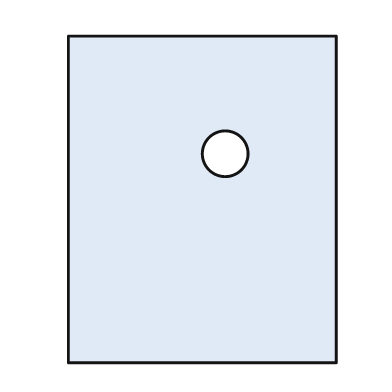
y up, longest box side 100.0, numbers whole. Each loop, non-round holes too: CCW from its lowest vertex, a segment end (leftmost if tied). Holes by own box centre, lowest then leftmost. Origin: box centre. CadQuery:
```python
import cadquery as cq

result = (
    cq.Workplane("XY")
    .moveTo(-41.0, -50.0)
    .lineTo(41.0, -50.0)
    .lineTo(41.0, 50.0)
    .lineTo(-41.0, 50.0)
    .close()
    .moveTo(7.0, 14.0)
    .circle(7.0)
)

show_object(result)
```